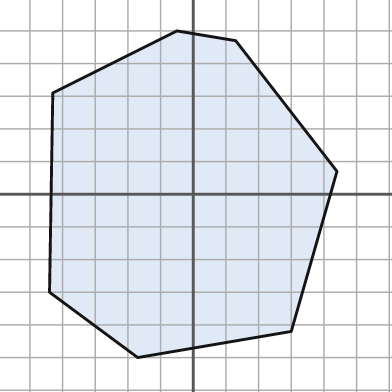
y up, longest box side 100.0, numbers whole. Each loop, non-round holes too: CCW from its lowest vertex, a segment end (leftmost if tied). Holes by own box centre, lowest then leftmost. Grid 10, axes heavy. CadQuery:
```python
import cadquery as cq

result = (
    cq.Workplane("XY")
    .moveTo(-17.0, -50.0)
    .lineTo(30.0, -42.0)
    .lineTo(44.0, 7.0)
    .lineTo(13.0, 47.0)
    .lineTo(-5.0, 50.0)
    .lineTo(-43.0, 31.0)
    .lineTo(-44.0, -30.0)
    .close()
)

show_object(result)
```